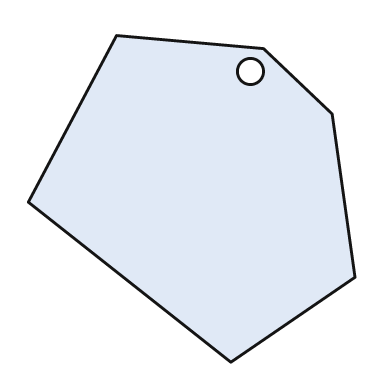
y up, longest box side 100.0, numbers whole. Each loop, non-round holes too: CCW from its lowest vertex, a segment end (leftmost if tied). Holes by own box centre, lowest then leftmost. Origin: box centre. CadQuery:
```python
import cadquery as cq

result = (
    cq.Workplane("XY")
    .moveTo(12.0, -50.0)
    .lineTo(50.0, -24.0)
    .lineTo(43.0, 26.0)
    .lineTo(22.0, 46.0)
    .lineTo(-23.0, 50.0)
    .lineTo(-50.0, -1.0)
    .close()
    .moveTo(18.0, 39.0)
    .circle(4.0)
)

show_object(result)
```